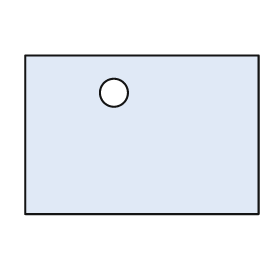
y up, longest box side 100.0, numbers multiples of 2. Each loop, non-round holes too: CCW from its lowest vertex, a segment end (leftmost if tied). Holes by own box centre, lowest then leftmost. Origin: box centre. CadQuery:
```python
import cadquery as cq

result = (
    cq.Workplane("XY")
    .moveTo(-50.0, -34.0)
    .lineTo(50.0, -34.0)
    .lineTo(50.0, 34.0)
    .lineTo(-50.0, 34.0)
    .close()
    .moveTo(-12.0, 18.0)
    .circle(6.0)
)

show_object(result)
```